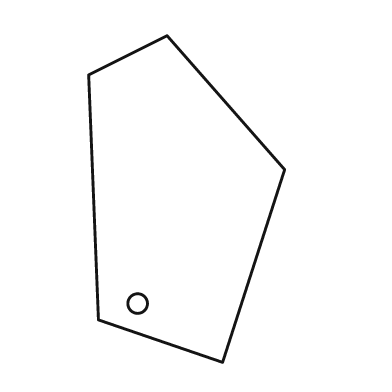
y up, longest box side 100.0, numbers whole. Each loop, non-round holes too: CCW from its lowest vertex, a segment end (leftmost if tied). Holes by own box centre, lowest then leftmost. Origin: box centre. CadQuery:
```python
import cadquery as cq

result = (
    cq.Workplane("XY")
    .moveTo(11.0, -50.0)
    .lineTo(30.0, 9.0)
    .lineTo(-6.0, 50.0)
    .lineTo(-30.0, 38.0)
    .lineTo(-27.0, -37.0)
    .close()
    .moveTo(-15.0, -32.0)
    .circle(3.0)
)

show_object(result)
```